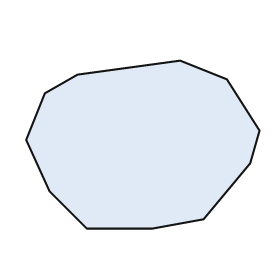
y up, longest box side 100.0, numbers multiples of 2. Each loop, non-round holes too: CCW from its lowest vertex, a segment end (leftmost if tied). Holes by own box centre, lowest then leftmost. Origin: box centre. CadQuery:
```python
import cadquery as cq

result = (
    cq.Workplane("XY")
    .moveTo(-24.0, -36.0)
    .lineTo(4.0, -36.0)
    .lineTo(26.0, -32.0)
    .lineTo(46.0, -8.0)
    .lineTo(50.0, 6.0)
    .lineTo(36.0, 28.0)
    .lineTo(16.0, 36.0)
    .lineTo(-28.0, 30.0)
    .lineTo(-42.0, 22.0)
    .lineTo(-50.0, 2.0)
    .lineTo(-40.0, -20.0)
    .close()
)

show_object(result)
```